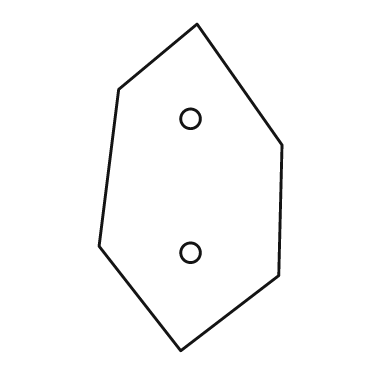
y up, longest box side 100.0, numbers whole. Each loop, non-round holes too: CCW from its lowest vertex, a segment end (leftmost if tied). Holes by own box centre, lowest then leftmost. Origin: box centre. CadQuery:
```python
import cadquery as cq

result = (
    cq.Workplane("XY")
    .moveTo(-3.0, -50.0)
    .lineTo(27.0, -27.0)
    .lineTo(28.0, 13.0)
    .lineTo(2.0, 50.0)
    .lineTo(-22.0, 30.0)
    .lineTo(-28.0, -18.0)
    .close()
    .moveTo(0.0, -20.0)
    .circle(3.0)
    .moveTo(0.0, 21.0)
    .circle(3.0)
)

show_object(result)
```